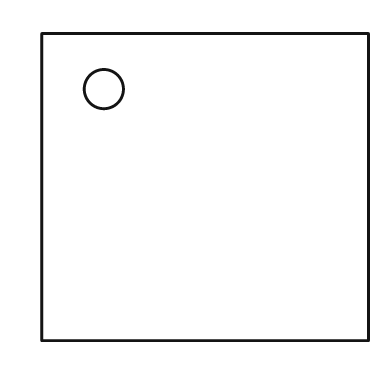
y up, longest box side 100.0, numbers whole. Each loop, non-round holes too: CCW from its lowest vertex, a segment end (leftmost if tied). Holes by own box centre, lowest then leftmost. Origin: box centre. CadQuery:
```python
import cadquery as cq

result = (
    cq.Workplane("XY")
    .moveTo(-50.0, -47.0)
    .lineTo(50.0, -47.0)
    .lineTo(50.0, 47.0)
    .lineTo(-50.0, 47.0)
    .close()
    .moveTo(-31.0, 30.0)
    .circle(6.0)
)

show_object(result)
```